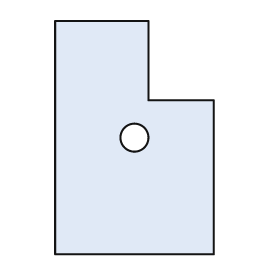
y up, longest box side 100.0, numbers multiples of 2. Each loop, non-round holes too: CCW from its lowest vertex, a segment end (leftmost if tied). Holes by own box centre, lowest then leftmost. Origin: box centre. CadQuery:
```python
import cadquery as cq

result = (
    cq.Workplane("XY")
    .moveTo(-34.0, -50.0)
    .lineTo(34.0, -50.0)
    .lineTo(34.0, 16.0)
    .lineTo(6.0, 16.0)
    .lineTo(6.0, 50.0)
    .lineTo(-34.0, 50.0)
    .close()
    .moveTo(0.0, 0.0)
    .circle(6.0)
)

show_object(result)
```